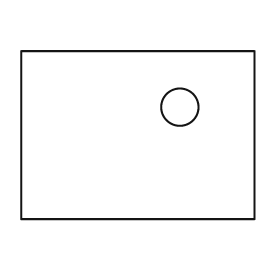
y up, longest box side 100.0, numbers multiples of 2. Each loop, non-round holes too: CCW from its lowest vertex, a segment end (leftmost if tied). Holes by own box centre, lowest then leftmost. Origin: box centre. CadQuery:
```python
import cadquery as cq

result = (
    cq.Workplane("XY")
    .moveTo(-50.0, -36.0)
    .lineTo(50.0, -36.0)
    .lineTo(50.0, 36.0)
    .lineTo(-50.0, 36.0)
    .close()
    .moveTo(18.0, 12.0)
    .circle(8.0)
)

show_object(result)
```